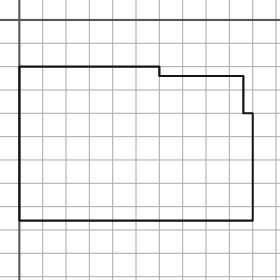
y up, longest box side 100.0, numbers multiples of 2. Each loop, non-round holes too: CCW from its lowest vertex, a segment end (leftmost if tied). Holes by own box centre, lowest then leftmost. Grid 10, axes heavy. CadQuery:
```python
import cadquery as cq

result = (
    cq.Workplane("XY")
    .moveTo(0.0, -86.0)
    .lineTo(100.0, -86.0)
    .lineTo(100.0, -40.0)
    .lineTo(96.0, -40.0)
    .lineTo(96.0, -24.0)
    .lineTo(60.0, -24.0)
    .lineTo(60.0, -20.0)
    .lineTo(0.0, -20.0)
    .close()
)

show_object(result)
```